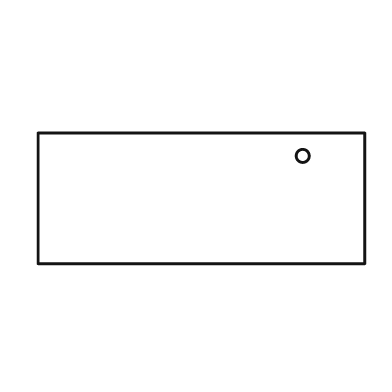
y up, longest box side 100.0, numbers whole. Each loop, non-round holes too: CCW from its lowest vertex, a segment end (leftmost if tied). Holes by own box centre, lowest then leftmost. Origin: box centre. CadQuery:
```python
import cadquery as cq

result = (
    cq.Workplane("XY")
    .moveTo(-50.0, -20.0)
    .lineTo(50.0, -20.0)
    .lineTo(50.0, 20.0)
    .lineTo(-50.0, 20.0)
    .close()
    .moveTo(31.0, 13.0)
    .circle(2.0)
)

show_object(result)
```